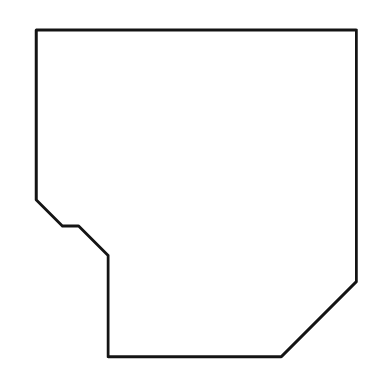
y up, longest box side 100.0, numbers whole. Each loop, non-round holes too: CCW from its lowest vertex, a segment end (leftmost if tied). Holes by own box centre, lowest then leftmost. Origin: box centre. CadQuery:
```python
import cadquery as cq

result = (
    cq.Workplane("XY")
    .moveTo(-27.0, -50.0)
    .lineTo(26.0, -50.0)
    .lineTo(49.0, -27.0)
    .lineTo(49.0, 50.0)
    .lineTo(-49.0, 50.0)
    .lineTo(-49.0, -2.0)
    .lineTo(-41.0, -10.0)
    .lineTo(-36.0, -10.0)
    .lineTo(-27.0, -19.0)
    .close()
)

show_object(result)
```